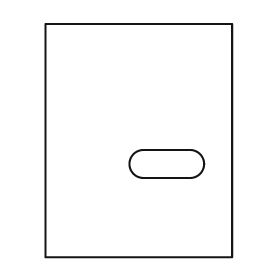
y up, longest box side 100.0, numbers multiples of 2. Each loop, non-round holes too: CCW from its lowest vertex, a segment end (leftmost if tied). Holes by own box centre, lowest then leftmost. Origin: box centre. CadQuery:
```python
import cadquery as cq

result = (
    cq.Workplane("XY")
    .moveTo(-40.0, -50.0)
    .lineTo(40.0, -50.0)
    .lineTo(40.0, 50.0)
    .lineTo(-40.0, 50.0)
    .close()
    .moveTo(2.0, -16.0)
    .lineTo(22.0, -16.0)
    .threePointArc((28.0, -10.0), (22.0, -4.0))
    .lineTo(2.0, -4.0)
    .threePointArc((-4.0, -10.0), (2.0, -16.0))
    .close()
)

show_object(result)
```